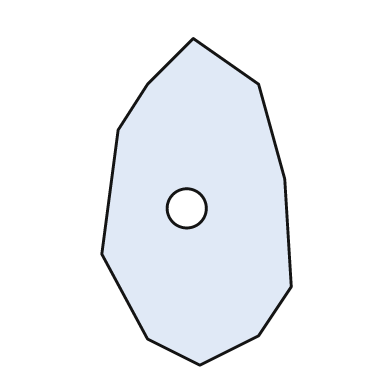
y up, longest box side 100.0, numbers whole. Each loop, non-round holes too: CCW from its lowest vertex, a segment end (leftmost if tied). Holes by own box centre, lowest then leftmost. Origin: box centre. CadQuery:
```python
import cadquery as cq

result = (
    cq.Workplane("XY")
    .moveTo(1.0, -50.0)
    .lineTo(19.0, -41.0)
    .lineTo(29.0, -26.0)
    .lineTo(27.0, 7.0)
    .lineTo(19.0, 36.0)
    .lineTo(-1.0, 50.0)
    .lineTo(-15.0, 36.0)
    .lineTo(-24.0, 22.0)
    .lineTo(-29.0, -16.0)
    .lineTo(-15.0, -42.0)
    .close()
    .moveTo(-3.0, -2.0)
    .circle(6.0)
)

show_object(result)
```